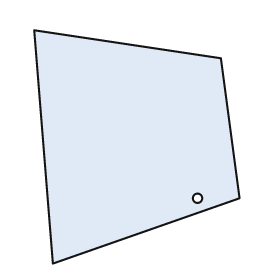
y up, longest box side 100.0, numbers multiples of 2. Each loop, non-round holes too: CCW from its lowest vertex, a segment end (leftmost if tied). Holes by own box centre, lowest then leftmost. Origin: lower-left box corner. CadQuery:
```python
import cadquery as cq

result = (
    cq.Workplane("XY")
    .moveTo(8.0, 0.0)
    .lineTo(88.0, 28.0)
    .lineTo(80.0, 88.0)
    .lineTo(0.0, 100.0)
    .close()
    .moveTo(70.0, 28.0)
    .circle(2.0)
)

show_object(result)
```